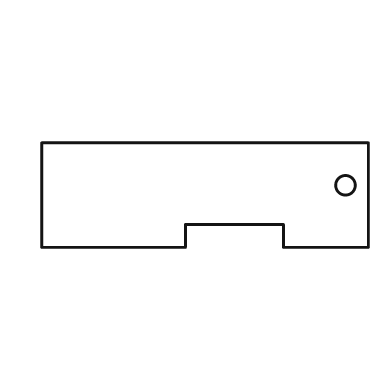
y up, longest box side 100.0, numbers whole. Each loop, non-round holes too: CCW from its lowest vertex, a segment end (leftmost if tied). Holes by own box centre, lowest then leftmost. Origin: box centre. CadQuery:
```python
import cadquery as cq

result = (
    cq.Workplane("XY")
    .moveTo(-50.0, -16.0)
    .lineTo(-6.0, -16.0)
    .lineTo(-6.0, -9.0)
    .lineTo(24.0, -9.0)
    .lineTo(24.0, -16.0)
    .lineTo(50.0, -16.0)
    .lineTo(50.0, 16.0)
    .lineTo(-50.0, 16.0)
    .close()
    .moveTo(43.0, 3.0)
    .circle(3.0)
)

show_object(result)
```